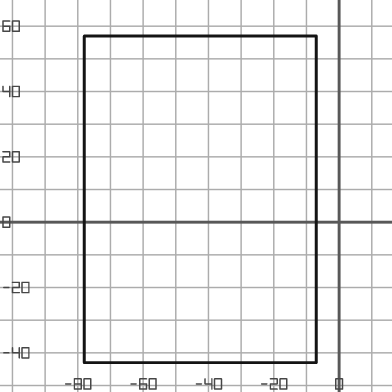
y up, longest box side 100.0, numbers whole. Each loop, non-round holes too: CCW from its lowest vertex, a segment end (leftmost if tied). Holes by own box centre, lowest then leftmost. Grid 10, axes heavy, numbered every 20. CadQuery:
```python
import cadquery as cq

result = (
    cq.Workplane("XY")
    .moveTo(-78.0, -43.0)
    .lineTo(-7.0, -43.0)
    .lineTo(-7.0, 57.0)
    .lineTo(-78.0, 57.0)
    .close()
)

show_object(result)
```